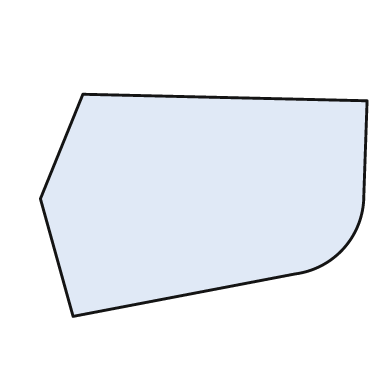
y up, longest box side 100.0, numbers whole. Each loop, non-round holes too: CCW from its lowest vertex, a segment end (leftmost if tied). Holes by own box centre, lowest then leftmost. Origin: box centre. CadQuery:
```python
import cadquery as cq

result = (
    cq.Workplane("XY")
    .moveTo(-40.0, -34.0)
    .lineTo(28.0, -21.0)
    .threePointArc((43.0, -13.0), (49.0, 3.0))
    .lineTo(50.0, 32.0)
    .lineTo(-37.0, 34.0)
    .lineTo(-50.0, 2.0)
    .close()
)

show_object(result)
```